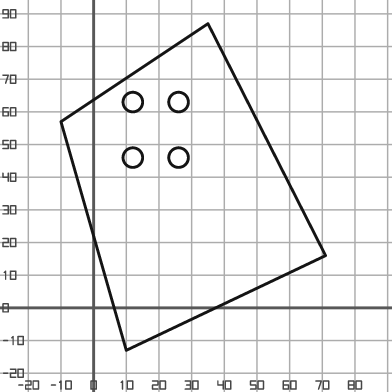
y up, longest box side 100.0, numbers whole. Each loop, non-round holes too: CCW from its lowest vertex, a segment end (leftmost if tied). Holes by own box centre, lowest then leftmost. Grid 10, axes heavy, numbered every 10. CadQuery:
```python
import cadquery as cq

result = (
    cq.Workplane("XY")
    .moveTo(10.0, -13.0)
    .lineTo(71.0, 16.0)
    .lineTo(35.0, 87.0)
    .lineTo(-10.0, 57.0)
    .close()
    .moveTo(12.0, 46.0)
    .circle(3.0)
    .moveTo(26.0, 46.0)
    .circle(3.0)
    .moveTo(12.0, 63.0)
    .circle(3.0)
    .moveTo(26.0, 63.0)
    .circle(3.0)
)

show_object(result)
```